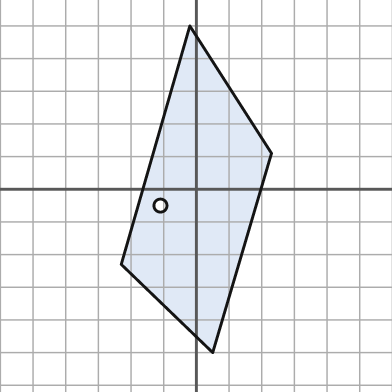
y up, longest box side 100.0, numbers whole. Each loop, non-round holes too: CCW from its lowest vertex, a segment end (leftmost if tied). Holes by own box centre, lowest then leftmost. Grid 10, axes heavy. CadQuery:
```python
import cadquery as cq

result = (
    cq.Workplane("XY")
    .moveTo(5.0, -50.0)
    .lineTo(23.0, 11.0)
    .lineTo(-2.0, 50.0)
    .lineTo(-23.0, -23.0)
    .close()
    .moveTo(-11.0, -5.0)
    .circle(2.0)
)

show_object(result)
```